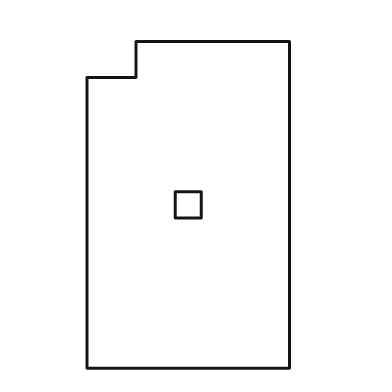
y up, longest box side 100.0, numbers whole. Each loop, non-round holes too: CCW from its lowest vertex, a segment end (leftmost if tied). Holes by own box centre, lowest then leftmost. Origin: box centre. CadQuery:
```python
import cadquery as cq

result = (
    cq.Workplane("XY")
    .moveTo(-31.0, -50.0)
    .lineTo(31.0, -50.0)
    .lineTo(31.0, 50.0)
    .lineTo(-16.0, 50.0)
    .lineTo(-16.0, 39.0)
    .lineTo(-31.0, 39.0)
    .close()
    .moveTo(-4.0, -4.0)
    .lineTo(4.0, -4.0)
    .lineTo(4.0, 4.0)
    .lineTo(-4.0, 4.0)
    .close()
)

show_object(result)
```